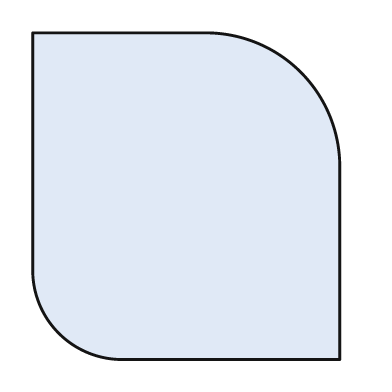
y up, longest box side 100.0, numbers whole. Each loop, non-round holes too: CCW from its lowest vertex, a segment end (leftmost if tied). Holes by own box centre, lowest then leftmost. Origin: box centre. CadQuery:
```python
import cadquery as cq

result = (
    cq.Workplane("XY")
    .moveTo(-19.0, -50.0)
    .lineTo(47.0, -50.0)
    .lineTo(47.0, 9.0)
    .threePointArc((35.0, 38.0), (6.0, 50.0))
    .lineTo(-47.0, 50.0)
    .lineTo(-47.0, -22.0)
    .threePointArc((-39.0, -42.0), (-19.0, -50.0))
    .close()
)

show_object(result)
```